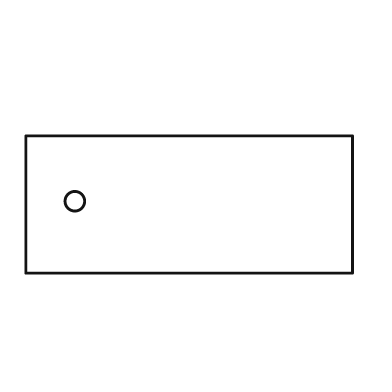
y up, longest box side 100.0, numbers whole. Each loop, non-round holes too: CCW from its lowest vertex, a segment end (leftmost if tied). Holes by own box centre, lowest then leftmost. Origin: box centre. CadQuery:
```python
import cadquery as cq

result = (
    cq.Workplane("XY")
    .moveTo(-50.0, -21.0)
    .lineTo(50.0, -21.0)
    .lineTo(50.0, 21.0)
    .lineTo(-50.0, 21.0)
    .close()
    .moveTo(-35.0, 1.0)
    .circle(3.0)
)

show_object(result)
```